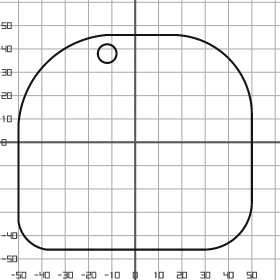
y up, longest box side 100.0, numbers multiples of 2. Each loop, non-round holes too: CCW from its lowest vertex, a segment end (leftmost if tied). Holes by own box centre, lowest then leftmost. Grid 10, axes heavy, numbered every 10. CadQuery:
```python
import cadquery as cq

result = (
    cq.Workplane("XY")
    .moveTo(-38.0, -46.0)
    .lineTo(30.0, -46.0)
    .threePointArc((44.0, -40.0), (50.0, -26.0))
    .lineTo(50.0, 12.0)
    .threePointArc((40.0, 36.0), (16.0, 46.0))
    .lineTo(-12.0, 46.0)
    .threePointArc((-38.0, 34.0), (-50.0, 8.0))
    .lineTo(-50.0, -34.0)
    .threePointArc((-46.0, -42.0), (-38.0, -46.0))
    .close()
    .moveTo(-12.0, 38.0)
    .circle(4.0)
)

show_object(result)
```